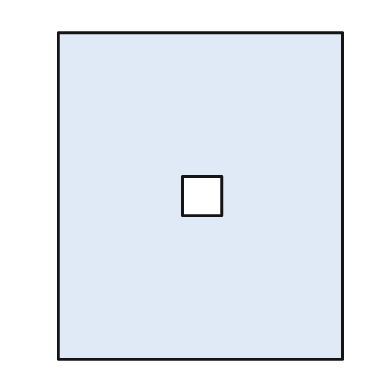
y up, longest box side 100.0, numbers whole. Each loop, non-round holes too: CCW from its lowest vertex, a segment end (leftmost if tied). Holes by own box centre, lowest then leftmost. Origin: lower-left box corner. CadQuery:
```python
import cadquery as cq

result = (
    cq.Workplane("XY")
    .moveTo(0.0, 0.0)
    .lineTo(87.0, 0.0)
    .lineTo(87.0, 100.0)
    .lineTo(0.0, 100.0)
    .close()
    .moveTo(38.0, 44.0)
    .lineTo(50.0, 44.0)
    .lineTo(50.0, 56.0)
    .lineTo(38.0, 56.0)
    .close()
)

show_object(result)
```